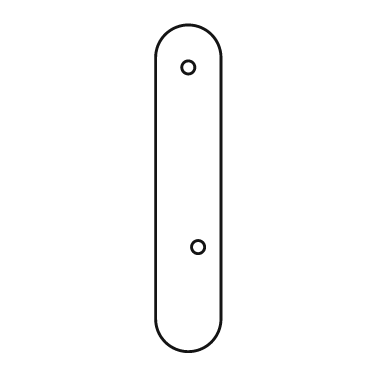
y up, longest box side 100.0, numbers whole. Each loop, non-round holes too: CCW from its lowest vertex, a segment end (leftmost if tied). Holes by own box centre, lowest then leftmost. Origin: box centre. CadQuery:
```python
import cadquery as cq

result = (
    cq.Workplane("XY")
    .moveTo(-10.0, -40.0)
    .threePointArc((0.0, -50.0), (10.0, -40.0))
    .lineTo(10.0, 40.0)
    .threePointArc((0.0, 50.0), (-10.0, 40.0))
    .close()
    .moveTo(3.0, -18.0)
    .circle(2.0)
    .moveTo(0.0, 37.0)
    .circle(2.0)
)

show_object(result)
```